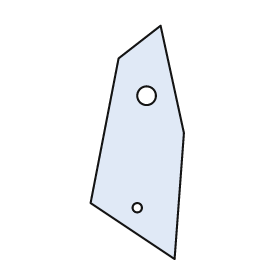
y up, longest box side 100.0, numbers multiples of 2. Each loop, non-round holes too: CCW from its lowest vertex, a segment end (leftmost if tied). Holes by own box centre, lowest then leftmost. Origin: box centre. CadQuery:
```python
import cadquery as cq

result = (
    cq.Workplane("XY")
    .moveTo(16.0, -50.0)
    .lineTo(20.0, 4.0)
    .lineTo(10.0, 50.0)
    .lineTo(-8.0, 36.0)
    .lineTo(-20.0, -26.0)
    .close()
    .moveTo(0.0, -28.0)
    .circle(2.0)
    .moveTo(4.0, 20.0)
    .circle(4.0)
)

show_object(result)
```